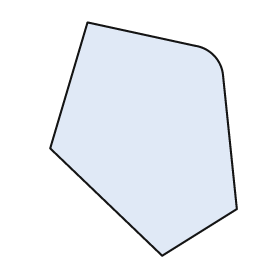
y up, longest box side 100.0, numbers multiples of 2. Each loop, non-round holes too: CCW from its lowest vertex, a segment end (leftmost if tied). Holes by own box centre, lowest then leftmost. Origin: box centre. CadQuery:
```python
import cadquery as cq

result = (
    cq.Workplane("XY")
    .moveTo(8.0, -50.0)
    .lineTo(40.0, -30.0)
    .lineTo(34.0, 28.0)
    .threePointArc((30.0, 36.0), (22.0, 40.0))
    .lineTo(-24.0, 50.0)
    .lineTo(-40.0, -4.0)
    .close()
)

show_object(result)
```